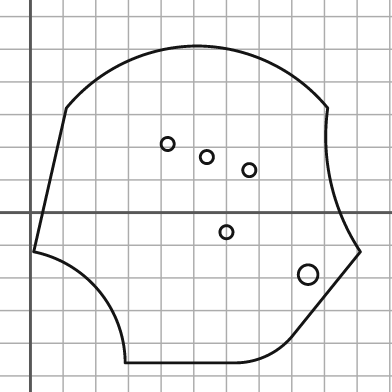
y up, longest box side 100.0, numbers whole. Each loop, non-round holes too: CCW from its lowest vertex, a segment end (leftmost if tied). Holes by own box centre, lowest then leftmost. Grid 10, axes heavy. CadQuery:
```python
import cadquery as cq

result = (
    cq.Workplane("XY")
    .moveTo(29.0, -46.0)
    .lineTo(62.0, -46.0)
    .threePointArc((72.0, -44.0), (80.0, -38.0))
    .lineTo(101.0, -12.0)
    .threePointArc((92.0, 9.0), (91.0, 32.0))
    .threePointArc((73.0, 46.0), (51.0, 51.0))
    .threePointArc((29.0, 46.0), (11.0, 32.0))
    .lineTo(1.0, -12.0)
    .threePointArc((21.0, -24.0), (29.0, -46.0))
    .close()
    .moveTo(85.0, -19.0)
    .circle(3.0)
    .moveTo(60.0, -6.0)
    .circle(2.0)
    .moveTo(67.0, 13.0)
    .circle(2.0)
    .moveTo(54.0, 17.0)
    .circle(2.0)
    .moveTo(42.0, 21.0)
    .circle(2.0)
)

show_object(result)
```